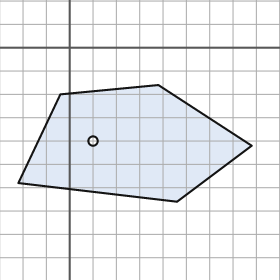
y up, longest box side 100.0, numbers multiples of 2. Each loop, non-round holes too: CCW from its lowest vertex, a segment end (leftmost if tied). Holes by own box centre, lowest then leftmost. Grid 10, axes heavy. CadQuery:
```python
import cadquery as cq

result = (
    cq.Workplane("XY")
    .moveTo(46.0, -66.0)
    .lineTo(78.0, -42.0)
    .lineTo(38.0, -16.0)
    .lineTo(-4.0, -20.0)
    .lineTo(-22.0, -58.0)
    .close()
    .moveTo(10.0, -40.0)
    .circle(2.0)
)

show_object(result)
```